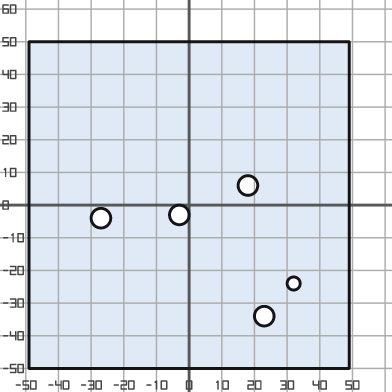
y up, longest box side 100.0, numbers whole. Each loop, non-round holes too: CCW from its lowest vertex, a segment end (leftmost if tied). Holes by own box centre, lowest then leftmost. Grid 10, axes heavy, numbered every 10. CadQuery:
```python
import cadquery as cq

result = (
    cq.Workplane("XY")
    .moveTo(-49.0, -50.0)
    .lineTo(49.0, -50.0)
    .lineTo(49.0, 50.0)
    .lineTo(-49.0, 50.0)
    .close()
    .moveTo(23.0, -34.0)
    .circle(3.0)
    .moveTo(32.0, -24.0)
    .circle(2.0)
    .moveTo(-27.0, -4.0)
    .circle(3.0)
    .moveTo(-3.0, -3.0)
    .circle(3.0)
    .moveTo(18.0, 6.0)
    .circle(3.0)
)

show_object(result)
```